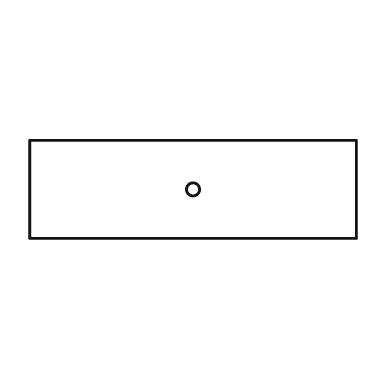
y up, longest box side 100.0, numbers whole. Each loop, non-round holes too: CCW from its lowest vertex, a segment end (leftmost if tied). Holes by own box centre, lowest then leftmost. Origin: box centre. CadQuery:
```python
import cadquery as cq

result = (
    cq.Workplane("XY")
    .moveTo(-50.0, -15.0)
    .lineTo(50.0, -15.0)
    .lineTo(50.0, 15.0)
    .lineTo(-50.0, 15.0)
    .close()
    .moveTo(0.0, 0.0)
    .circle(2.0)
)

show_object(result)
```